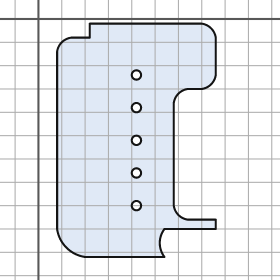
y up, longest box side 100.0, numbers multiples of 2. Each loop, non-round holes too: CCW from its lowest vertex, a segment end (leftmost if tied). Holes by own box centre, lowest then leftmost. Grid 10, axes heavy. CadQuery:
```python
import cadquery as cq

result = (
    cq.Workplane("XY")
    .moveTo(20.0, -102.0)
    .lineTo(54.0, -102.0)
    .threePointArc((52.0, -96.0), (54.0, -90.0))
    .lineTo(76.0, -90.0)
    .lineTo(76.0, -86.0)
    .lineTo(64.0, -86.0)
    .threePointArc((60.0, -84.0), (58.0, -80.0))
    .lineTo(58.0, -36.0)
    .threePointArc((60.0, -32.0), (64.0, -30.0))
    .lineTo(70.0, -30.0)
    .threePointArc((74.0, -28.0), (76.0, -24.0))
    .lineTo(76.0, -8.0)
    .threePointArc((74.0, -4.0), (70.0, -2.0))
    .lineTo(22.0, -2.0)
    .lineTo(22.0, -8.0)
    .lineTo(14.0, -8.0)
    .threePointArc((10.0, -10.0), (8.0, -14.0))
    .lineTo(8.0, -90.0)
    .threePointArc((12.0, -98.0), (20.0, -102.0))
    .close()
    .moveTo(42.0, -80.0)
    .circle(2.0)
    .moveTo(42.0, -66.0)
    .circle(2.0)
    .moveTo(42.0, -52.0)
    .circle(2.0)
    .moveTo(42.0, -38.0)
    .circle(2.0)
    .moveTo(42.0, -24.0)
    .circle(2.0)
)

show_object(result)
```